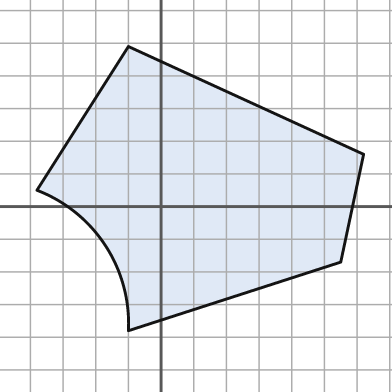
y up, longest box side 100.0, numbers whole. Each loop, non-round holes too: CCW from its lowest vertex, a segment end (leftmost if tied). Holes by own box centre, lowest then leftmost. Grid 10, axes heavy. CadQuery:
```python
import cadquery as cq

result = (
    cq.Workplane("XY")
    .moveTo(-10.0, -38.0)
    .lineTo(55.0, -17.0)
    .lineTo(62.0, 16.0)
    .lineTo(-10.0, 49.0)
    .lineTo(-38.0, 5.0)
    .threePointArc((-17.0, -12.0), (-10.0, -38.0))
    .close()
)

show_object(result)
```